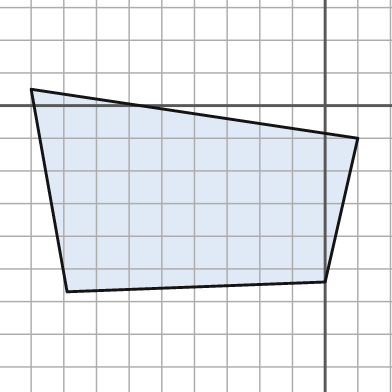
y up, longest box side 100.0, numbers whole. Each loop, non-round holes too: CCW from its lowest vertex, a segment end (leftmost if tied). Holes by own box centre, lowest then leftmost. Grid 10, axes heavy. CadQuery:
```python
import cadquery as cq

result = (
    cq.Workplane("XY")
    .moveTo(-79.0, -57.0)
    .lineTo(0.0, -54.0)
    .lineTo(10.0, -10.0)
    .lineTo(-90.0, 5.0)
    .close()
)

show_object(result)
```